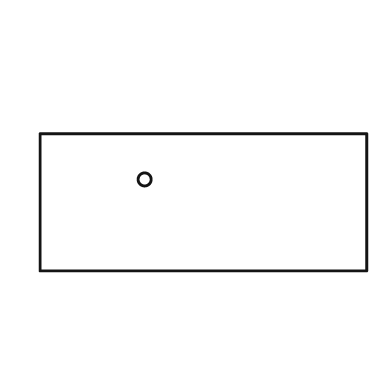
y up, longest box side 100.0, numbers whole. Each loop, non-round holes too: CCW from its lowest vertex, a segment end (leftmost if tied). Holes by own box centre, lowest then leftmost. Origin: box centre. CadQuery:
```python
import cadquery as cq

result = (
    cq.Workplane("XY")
    .moveTo(-50.0, -21.0)
    .lineTo(50.0, -21.0)
    .lineTo(50.0, 21.0)
    .lineTo(-50.0, 21.0)
    .close()
    .moveTo(-18.0, 7.0)
    .circle(2.0)
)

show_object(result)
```